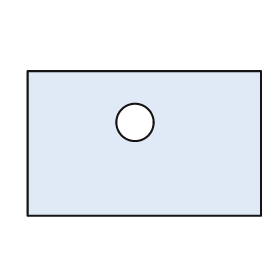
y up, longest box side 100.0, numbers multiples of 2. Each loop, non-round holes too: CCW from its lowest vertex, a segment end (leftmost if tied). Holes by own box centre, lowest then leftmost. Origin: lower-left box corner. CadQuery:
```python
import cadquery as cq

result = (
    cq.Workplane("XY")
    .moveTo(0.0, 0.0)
    .lineTo(100.0, 0.0)
    .lineTo(100.0, 62.0)
    .lineTo(0.0, 62.0)
    .close()
    .moveTo(46.0, 40.0)
    .circle(8.0)
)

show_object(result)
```